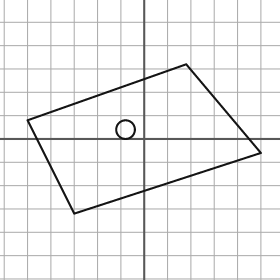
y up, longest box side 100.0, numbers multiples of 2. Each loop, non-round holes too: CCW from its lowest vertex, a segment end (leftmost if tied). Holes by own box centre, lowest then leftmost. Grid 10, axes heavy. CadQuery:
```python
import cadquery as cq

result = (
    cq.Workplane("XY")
    .moveTo(-30.0, -32.0)
    .lineTo(50.0, -6.0)
    .lineTo(18.0, 32.0)
    .lineTo(-50.0, 8.0)
    .close()
    .moveTo(-8.0, 4.0)
    .circle(4.0)
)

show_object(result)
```